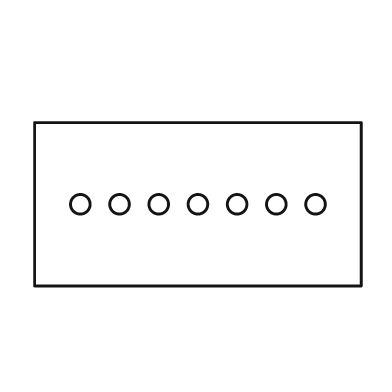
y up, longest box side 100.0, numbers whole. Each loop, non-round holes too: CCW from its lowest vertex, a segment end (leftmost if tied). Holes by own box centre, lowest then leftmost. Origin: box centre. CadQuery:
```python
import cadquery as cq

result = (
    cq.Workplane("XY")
    .moveTo(-50.0, -25.0)
    .lineTo(50.0, -25.0)
    .lineTo(50.0, 25.0)
    .lineTo(-50.0, 25.0)
    .close()
    .moveTo(-36.0, 0.0)
    .circle(3.0)
    .moveTo(-24.0, 0.0)
    .circle(3.0)
    .moveTo(-12.0, 0.0)
    .circle(3.0)
    .moveTo(0.0, 0.0)
    .circle(3.0)
    .moveTo(12.0, 0.0)
    .circle(3.0)
    .moveTo(24.0, 0.0)
    .circle(3.0)
    .moveTo(36.0, 0.0)
    .circle(3.0)
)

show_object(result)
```